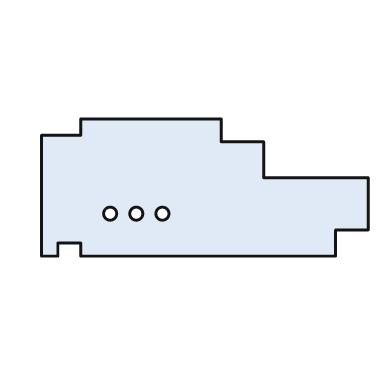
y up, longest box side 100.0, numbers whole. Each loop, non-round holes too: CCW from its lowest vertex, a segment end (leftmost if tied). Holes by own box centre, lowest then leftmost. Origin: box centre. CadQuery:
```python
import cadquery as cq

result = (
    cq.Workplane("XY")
    .moveTo(-50.0, -21.0)
    .lineTo(-45.0, -21.0)
    .lineTo(-45.0, -17.0)
    .lineTo(-38.0, -17.0)
    .lineTo(-38.0, -21.0)
    .lineTo(40.0, -21.0)
    .lineTo(40.0, -13.0)
    .lineTo(50.0, -13.0)
    .lineTo(50.0, 3.0)
    .lineTo(18.0, 3.0)
    .lineTo(18.0, 14.0)
    .lineTo(5.0, 14.0)
    .lineTo(5.0, 21.0)
    .lineTo(-38.0, 21.0)
    .lineTo(-38.0, 16.0)
    .lineTo(-50.0, 16.0)
    .close()
    .moveTo(-29.0, -8.0)
    .circle(2.0)
    .moveTo(-21.0, -8.0)
    .circle(2.0)
    .moveTo(-13.0, -8.0)
    .circle(2.0)
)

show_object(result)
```